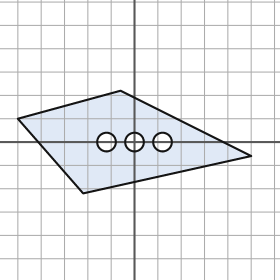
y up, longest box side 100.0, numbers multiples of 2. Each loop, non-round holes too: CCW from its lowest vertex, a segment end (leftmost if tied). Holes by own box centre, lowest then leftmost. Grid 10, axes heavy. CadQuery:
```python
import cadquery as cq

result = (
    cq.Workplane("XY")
    .moveTo(-22.0, -22.0)
    .lineTo(50.0, -6.0)
    .lineTo(-6.0, 22.0)
    .lineTo(-50.0, 10.0)
    .close()
    .moveTo(-12.0, 0.0)
    .circle(4.0)
    .moveTo(0.0, 0.0)
    .circle(4.0)
    .moveTo(12.0, 0.0)
    .circle(4.0)
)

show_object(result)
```